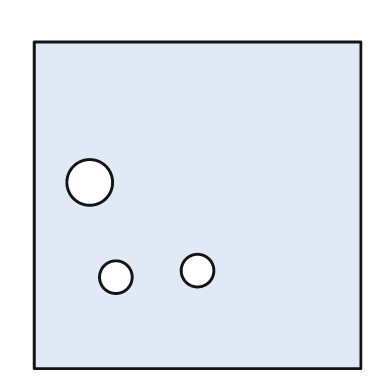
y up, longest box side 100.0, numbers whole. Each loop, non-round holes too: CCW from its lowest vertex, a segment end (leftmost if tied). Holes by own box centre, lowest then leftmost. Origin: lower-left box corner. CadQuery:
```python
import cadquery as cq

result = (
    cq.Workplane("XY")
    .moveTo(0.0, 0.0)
    .lineTo(100.0, 0.0)
    .lineTo(100.0, 100.0)
    .lineTo(0.0, 100.0)
    .close()
    .moveTo(25.0, 28.0)
    .circle(5.0)
    .moveTo(50.0, 30.0)
    .circle(5.0)
    .moveTo(17.0, 57.0)
    .circle(7.0)
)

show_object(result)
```